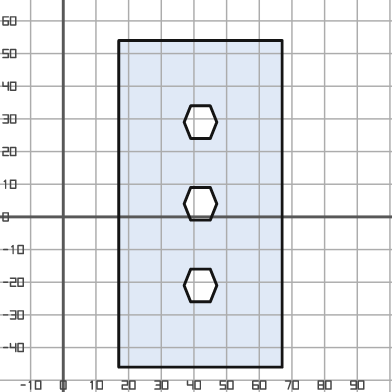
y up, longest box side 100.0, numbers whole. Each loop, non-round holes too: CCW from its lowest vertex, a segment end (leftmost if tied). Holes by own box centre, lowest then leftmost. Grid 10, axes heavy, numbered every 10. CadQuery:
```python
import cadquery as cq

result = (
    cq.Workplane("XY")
    .moveTo(17.0, -46.0)
    .lineTo(67.0, -46.0)
    .lineTo(67.0, 54.0)
    .lineTo(17.0, 54.0)
    .close()
    .moveTo(39.0, -26.0)
    .lineTo(45.0, -26.0)
    .lineTo(47.0, -21.0)
    .lineTo(45.0, -16.0)
    .lineTo(39.0, -16.0)
    .lineTo(37.0, -21.0)
    .close()
    .moveTo(39.0, -1.0)
    .lineTo(45.0, -1.0)
    .lineTo(47.0, 4.0)
    .lineTo(45.0, 9.0)
    .lineTo(39.0, 9.0)
    .lineTo(37.0, 4.0)
    .close()
    .moveTo(39.0, 24.0)
    .lineTo(45.0, 24.0)
    .lineTo(47.0, 29.0)
    .lineTo(45.0, 34.0)
    .lineTo(39.0, 34.0)
    .lineTo(37.0, 29.0)
    .close()
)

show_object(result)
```